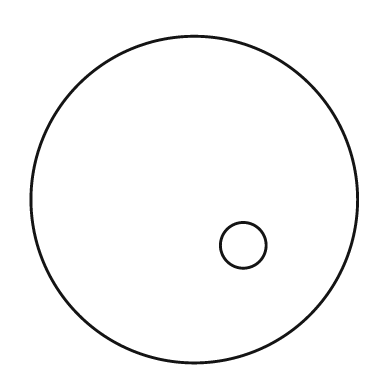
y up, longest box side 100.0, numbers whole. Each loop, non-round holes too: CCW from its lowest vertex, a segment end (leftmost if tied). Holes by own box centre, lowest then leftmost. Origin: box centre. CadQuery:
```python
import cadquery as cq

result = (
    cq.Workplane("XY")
    .moveTo(0.0, 0.0)
    .circle(50.0)
    .moveTo(15.0, -14.0)
    .circle(7.0)
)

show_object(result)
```